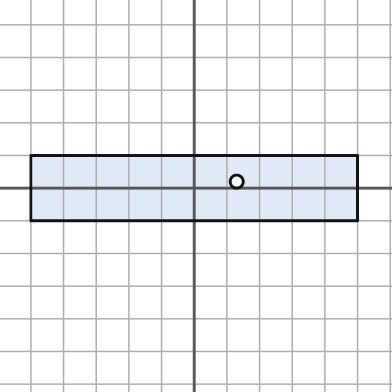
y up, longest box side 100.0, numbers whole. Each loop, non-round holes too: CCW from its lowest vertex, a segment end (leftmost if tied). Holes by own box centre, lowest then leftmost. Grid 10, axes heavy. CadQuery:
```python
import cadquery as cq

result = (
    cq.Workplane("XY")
    .moveTo(-50.0, -10.0)
    .lineTo(50.0, -10.0)
    .lineTo(50.0, 10.0)
    .lineTo(-50.0, 10.0)
    .close()
    .moveTo(13.0, 2.0)
    .circle(2.0)
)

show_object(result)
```